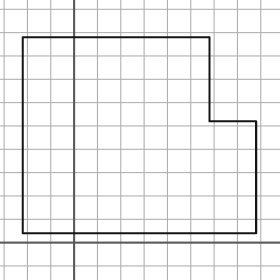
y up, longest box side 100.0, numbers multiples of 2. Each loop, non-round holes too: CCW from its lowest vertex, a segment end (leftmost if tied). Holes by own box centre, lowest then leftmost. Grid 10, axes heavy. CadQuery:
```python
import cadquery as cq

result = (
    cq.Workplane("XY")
    .moveTo(-22.0, 4.0)
    .lineTo(78.0, 4.0)
    .lineTo(78.0, 52.0)
    .lineTo(58.0, 52.0)
    .lineTo(58.0, 88.0)
    .lineTo(-22.0, 88.0)
    .close()
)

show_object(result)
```